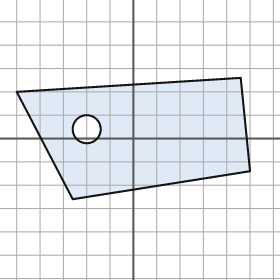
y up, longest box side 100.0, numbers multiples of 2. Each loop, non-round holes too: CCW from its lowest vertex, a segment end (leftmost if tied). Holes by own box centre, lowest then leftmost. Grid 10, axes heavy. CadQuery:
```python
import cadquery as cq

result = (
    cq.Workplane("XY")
    .moveTo(-26.0, -26.0)
    .lineTo(50.0, -14.0)
    .lineTo(46.0, 26.0)
    .lineTo(-50.0, 20.0)
    .close()
    .moveTo(-20.0, 4.0)
    .circle(6.0)
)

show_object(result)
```